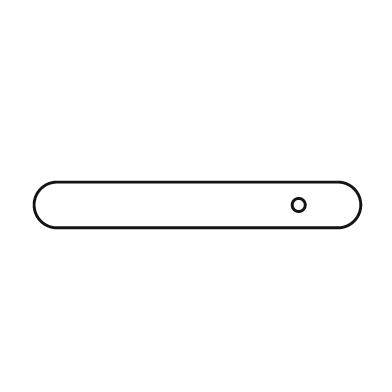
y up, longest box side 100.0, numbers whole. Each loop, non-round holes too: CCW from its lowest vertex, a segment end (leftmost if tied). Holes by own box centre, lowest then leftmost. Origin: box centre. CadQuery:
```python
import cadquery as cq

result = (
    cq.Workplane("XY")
    .moveTo(-43.0, -7.0)
    .lineTo(43.0, -7.0)
    .threePointArc((50.0, 0.0), (43.0, 7.0))
    .lineTo(-43.0, 7.0)
    .threePointArc((-50.0, 0.0), (-43.0, -7.0))
    .close()
    .moveTo(31.0, 0.0)
    .circle(2.0)
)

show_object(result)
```